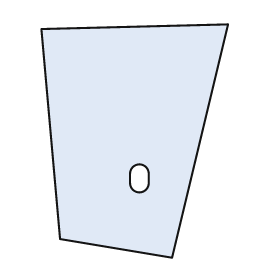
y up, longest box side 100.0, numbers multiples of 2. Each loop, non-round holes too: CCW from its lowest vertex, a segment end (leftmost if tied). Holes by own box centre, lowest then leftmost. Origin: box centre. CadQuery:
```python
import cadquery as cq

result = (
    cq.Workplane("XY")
    .moveTo(16.0, -50.0)
    .lineTo(40.0, 50.0)
    .lineTo(-40.0, 48.0)
    .lineTo(-32.0, -42.0)
    .close()
    .moveTo(-2.0, -18.0)
    .threePointArc((2.0, -22.0), (6.0, -18.0))
    .lineTo(6.0, -14.0)
    .threePointArc((2.0, -10.0), (-2.0, -14.0))
    .close()
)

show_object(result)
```